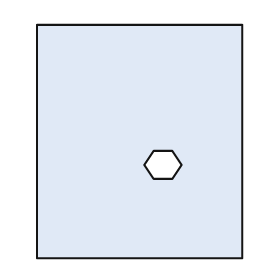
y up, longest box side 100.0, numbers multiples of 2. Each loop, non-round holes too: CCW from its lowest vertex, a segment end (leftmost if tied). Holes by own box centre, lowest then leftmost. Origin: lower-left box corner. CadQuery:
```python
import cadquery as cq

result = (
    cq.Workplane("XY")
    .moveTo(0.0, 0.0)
    .lineTo(88.0, 0.0)
    .lineTo(88.0, 100.0)
    .lineTo(0.0, 100.0)
    .close()
    .moveTo(50.0, 34.0)
    .lineTo(58.0, 34.0)
    .lineTo(62.0, 40.0)
    .lineTo(58.0, 46.0)
    .lineTo(50.0, 46.0)
    .lineTo(46.0, 40.0)
    .close()
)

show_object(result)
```